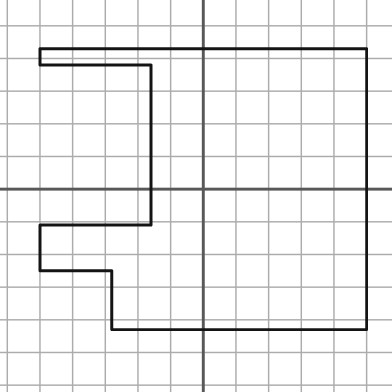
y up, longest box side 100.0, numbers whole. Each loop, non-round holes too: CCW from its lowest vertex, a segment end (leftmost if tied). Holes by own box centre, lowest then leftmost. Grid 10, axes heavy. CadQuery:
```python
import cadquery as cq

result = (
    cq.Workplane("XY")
    .moveTo(-28.0, -43.0)
    .lineTo(50.0, -43.0)
    .lineTo(50.0, 43.0)
    .lineTo(-50.0, 43.0)
    .lineTo(-50.0, 38.0)
    .lineTo(-16.0, 38.0)
    .lineTo(-16.0, -11.0)
    .lineTo(-50.0, -11.0)
    .lineTo(-50.0, -25.0)
    .lineTo(-28.0, -25.0)
    .close()
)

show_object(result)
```